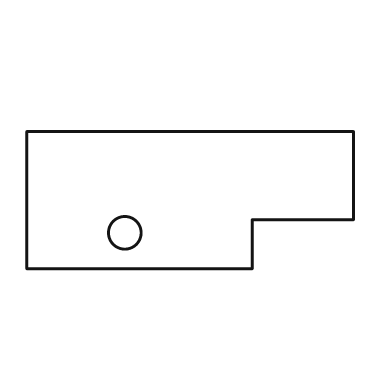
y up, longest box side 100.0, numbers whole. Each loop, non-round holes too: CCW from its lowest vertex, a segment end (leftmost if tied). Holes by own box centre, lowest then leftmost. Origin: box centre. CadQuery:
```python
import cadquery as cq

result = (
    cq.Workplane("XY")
    .moveTo(-50.0, -21.0)
    .lineTo(19.0, -21.0)
    .lineTo(19.0, -6.0)
    .lineTo(50.0, -6.0)
    .lineTo(50.0, 21.0)
    .lineTo(-50.0, 21.0)
    .close()
    .moveTo(-20.0, -10.0)
    .circle(5.0)
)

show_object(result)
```